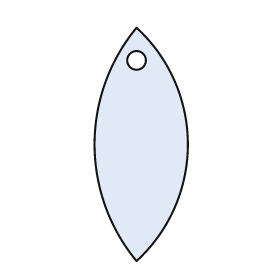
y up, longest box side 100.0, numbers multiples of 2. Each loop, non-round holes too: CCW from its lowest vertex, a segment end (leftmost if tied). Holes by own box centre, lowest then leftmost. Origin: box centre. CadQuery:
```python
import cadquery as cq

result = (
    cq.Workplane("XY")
    .moveTo(-2.0, -50.0)
    .threePointArc((20.0, 0.0), (-2.0, 50.0))
    .threePointArc((-20.0, 0.0), (-2.0, -50.0))
    .close()
    .moveTo(-2.0, 36.0)
    .circle(4.0)
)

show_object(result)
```